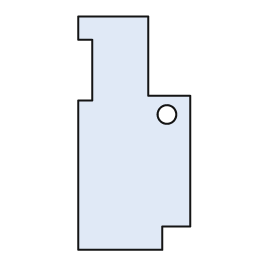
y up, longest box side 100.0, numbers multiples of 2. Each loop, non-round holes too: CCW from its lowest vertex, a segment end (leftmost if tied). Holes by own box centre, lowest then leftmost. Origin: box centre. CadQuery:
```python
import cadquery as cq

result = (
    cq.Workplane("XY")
    .moveTo(-24.0, -50.0)
    .lineTo(12.0, -50.0)
    .lineTo(12.0, -40.0)
    .lineTo(24.0, -40.0)
    .lineTo(24.0, 16.0)
    .lineTo(6.0, 16.0)
    .lineTo(6.0, 50.0)
    .lineTo(-24.0, 50.0)
    .lineTo(-24.0, 40.0)
    .lineTo(-18.0, 40.0)
    .lineTo(-18.0, 14.0)
    .lineTo(-24.0, 14.0)
    .close()
    .moveTo(14.0, 8.0)
    .circle(4.0)
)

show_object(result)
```